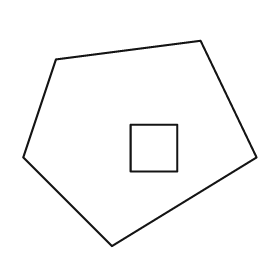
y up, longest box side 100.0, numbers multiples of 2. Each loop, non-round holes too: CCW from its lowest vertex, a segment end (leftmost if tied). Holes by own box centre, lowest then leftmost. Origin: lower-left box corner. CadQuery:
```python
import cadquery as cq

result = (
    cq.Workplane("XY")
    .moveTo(38.0, 0.0)
    .lineTo(100.0, 38.0)
    .lineTo(76.0, 88.0)
    .lineTo(14.0, 80.0)
    .lineTo(0.0, 38.0)
    .close()
    .moveTo(46.0, 32.0)
    .lineTo(66.0, 32.0)
    .lineTo(66.0, 52.0)
    .lineTo(46.0, 52.0)
    .close()
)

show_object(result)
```